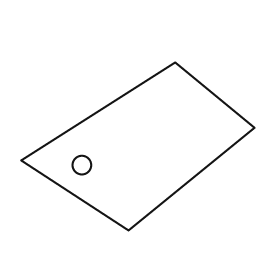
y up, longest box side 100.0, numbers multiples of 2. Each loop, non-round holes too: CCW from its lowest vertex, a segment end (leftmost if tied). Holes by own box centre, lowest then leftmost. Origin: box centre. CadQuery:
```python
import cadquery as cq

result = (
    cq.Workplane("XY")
    .moveTo(-4.0, -36.0)
    .lineTo(50.0, 8.0)
    .lineTo(16.0, 36.0)
    .lineTo(-50.0, -6.0)
    .close()
    .moveTo(-24.0, -8.0)
    .circle(4.0)
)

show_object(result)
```